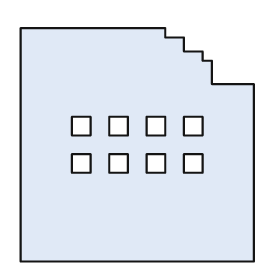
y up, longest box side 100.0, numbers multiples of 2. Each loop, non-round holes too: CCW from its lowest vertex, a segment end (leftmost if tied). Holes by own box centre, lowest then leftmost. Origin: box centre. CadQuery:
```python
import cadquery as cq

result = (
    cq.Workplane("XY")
    .moveTo(-50.0, -50.0)
    .lineTo(50.0, -50.0)
    .lineTo(50.0, 26.0)
    .lineTo(32.0, 26.0)
    .lineTo(32.0, 36.0)
    .lineTo(28.0, 36.0)
    .lineTo(28.0, 40.0)
    .lineTo(20.0, 40.0)
    .lineTo(20.0, 46.0)
    .lineTo(12.0, 46.0)
    .lineTo(12.0, 50.0)
    .lineTo(-50.0, 50.0)
    .close()
    .moveTo(-28.0, -12.0)
    .lineTo(-20.0, -12.0)
    .lineTo(-20.0, -4.0)
    .lineTo(-28.0, -4.0)
    .close()
    .moveTo(-12.0, -12.0)
    .lineTo(-4.0, -12.0)
    .lineTo(-4.0, -4.0)
    .lineTo(-12.0, -4.0)
    .close()
    .moveTo(4.0, -12.0)
    .lineTo(12.0, -12.0)
    .lineTo(12.0, -4.0)
    .lineTo(4.0, -4.0)
    .close()
    .moveTo(20.0, -12.0)
    .lineTo(28.0, -12.0)
    .lineTo(28.0, -4.0)
    .lineTo(20.0, -4.0)
    .close()
    .moveTo(-28.0, 4.0)
    .lineTo(-20.0, 4.0)
    .lineTo(-20.0, 12.0)
    .lineTo(-28.0, 12.0)
    .close()
    .moveTo(-12.0, 4.0)
    .lineTo(-4.0, 4.0)
    .lineTo(-4.0, 12.0)
    .lineTo(-12.0, 12.0)
    .close()
    .moveTo(4.0, 4.0)
    .lineTo(12.0, 4.0)
    .lineTo(12.0, 12.0)
    .lineTo(4.0, 12.0)
    .close()
    .moveTo(20.0, 4.0)
    .lineTo(28.0, 4.0)
    .lineTo(28.0, 12.0)
    .lineTo(20.0, 12.0)
    .close()
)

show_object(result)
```